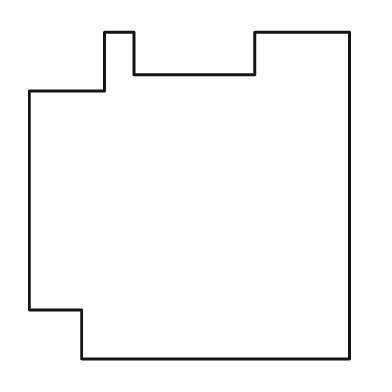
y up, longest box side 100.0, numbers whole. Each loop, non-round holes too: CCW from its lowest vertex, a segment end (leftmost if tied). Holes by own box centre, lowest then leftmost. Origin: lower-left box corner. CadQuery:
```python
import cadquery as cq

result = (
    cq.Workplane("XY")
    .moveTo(16.0, 0.0)
    .lineTo(98.0, 0.0)
    .lineTo(98.0, 100.0)
    .lineTo(69.0, 100.0)
    .lineTo(69.0, 87.0)
    .lineTo(32.0, 87.0)
    .lineTo(32.0, 100.0)
    .lineTo(23.0, 100.0)
    .lineTo(23.0, 82.0)
    .lineTo(0.0, 82.0)
    .lineTo(0.0, 15.0)
    .lineTo(16.0, 15.0)
    .close()
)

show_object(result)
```